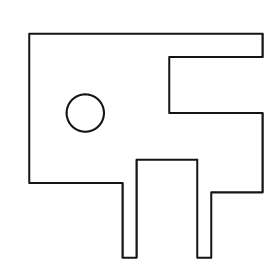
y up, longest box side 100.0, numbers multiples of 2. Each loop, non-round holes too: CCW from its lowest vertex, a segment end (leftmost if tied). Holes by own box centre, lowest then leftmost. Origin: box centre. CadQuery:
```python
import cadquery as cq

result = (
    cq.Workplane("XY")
    .moveTo(-10.0, -48.0)
    .lineTo(-4.0, -48.0)
    .lineTo(-4.0, -6.0)
    .lineTo(22.0, -6.0)
    .lineTo(22.0, -48.0)
    .lineTo(28.0, -48.0)
    .lineTo(28.0, -20.0)
    .lineTo(50.0, -20.0)
    .lineTo(50.0, 14.0)
    .lineTo(10.0, 14.0)
    .lineTo(10.0, 38.0)
    .lineTo(50.0, 38.0)
    .lineTo(50.0, 48.0)
    .lineTo(-50.0, 48.0)
    .lineTo(-50.0, -16.0)
    .lineTo(-10.0, -16.0)
    .close()
    .moveTo(-26.0, 14.0)
    .circle(8.0)
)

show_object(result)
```